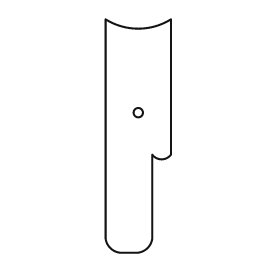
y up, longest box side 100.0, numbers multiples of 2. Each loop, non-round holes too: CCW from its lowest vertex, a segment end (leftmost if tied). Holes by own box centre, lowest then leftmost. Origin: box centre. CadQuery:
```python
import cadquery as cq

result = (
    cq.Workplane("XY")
    .moveTo(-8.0, -50.0)
    .lineTo(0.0, -50.0)
    .threePointArc((4.0, -48.0), (6.0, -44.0))
    .lineTo(6.0, -8.0)
    .threePointArc((10.0, -10.0), (14.0, -8.0))
    .lineTo(14.0, 50.0)
    .threePointArc((0.0, 46.0), (-14.0, 50.0))
    .lineTo(-14.0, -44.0)
    .threePointArc((-12.0, -48.0), (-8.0, -50.0))
    .close()
    .moveTo(0.0, 10.0)
    .circle(2.0)
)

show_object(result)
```